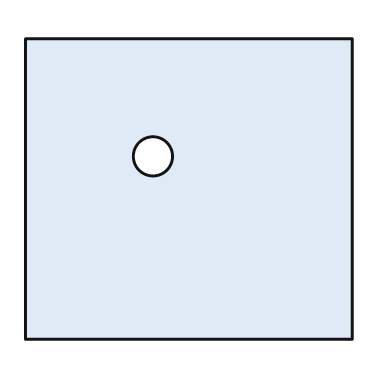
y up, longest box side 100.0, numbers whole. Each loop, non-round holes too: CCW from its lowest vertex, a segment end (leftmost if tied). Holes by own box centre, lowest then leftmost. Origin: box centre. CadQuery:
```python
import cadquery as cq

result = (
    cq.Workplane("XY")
    .moveTo(-50.0, -46.0)
    .lineTo(50.0, -46.0)
    .lineTo(50.0, 46.0)
    .lineTo(-50.0, 46.0)
    .close()
    .moveTo(-11.0, 10.0)
    .circle(6.0)
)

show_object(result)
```